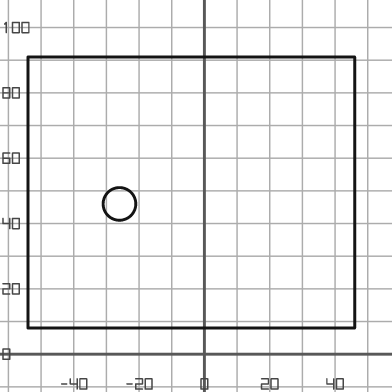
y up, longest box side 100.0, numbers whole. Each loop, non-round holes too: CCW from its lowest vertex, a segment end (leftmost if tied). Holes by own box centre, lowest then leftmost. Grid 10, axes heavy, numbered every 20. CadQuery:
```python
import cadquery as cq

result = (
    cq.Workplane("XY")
    .moveTo(-54.0, 8.0)
    .lineTo(46.0, 8.0)
    .lineTo(46.0, 91.0)
    .lineTo(-54.0, 91.0)
    .close()
    .moveTo(-26.0, 46.0)
    .circle(5.0)
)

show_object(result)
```